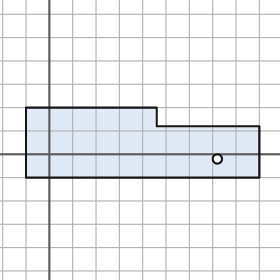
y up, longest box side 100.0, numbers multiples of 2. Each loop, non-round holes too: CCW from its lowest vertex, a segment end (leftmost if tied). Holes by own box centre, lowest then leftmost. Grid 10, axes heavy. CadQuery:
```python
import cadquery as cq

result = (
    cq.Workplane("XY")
    .moveTo(-10.0, -10.0)
    .lineTo(90.0, -10.0)
    .lineTo(90.0, 12.0)
    .lineTo(46.0, 12.0)
    .lineTo(46.0, 20.0)
    .lineTo(-10.0, 20.0)
    .close()
    .moveTo(72.0, -2.0)
    .circle(2.0)
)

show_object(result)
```